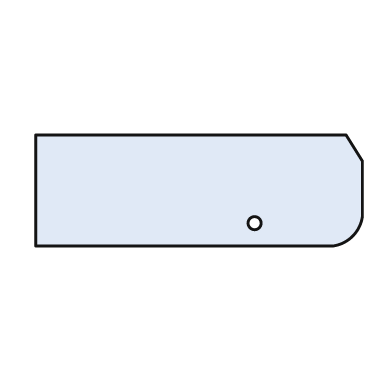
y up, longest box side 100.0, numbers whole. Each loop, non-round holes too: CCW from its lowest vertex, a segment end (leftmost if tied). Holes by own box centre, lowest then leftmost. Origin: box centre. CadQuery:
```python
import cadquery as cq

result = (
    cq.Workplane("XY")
    .moveTo(-50.0, -17.0)
    .lineTo(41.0, -17.0)
    .threePointArc((47.0, -14.0), (50.0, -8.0))
    .lineTo(50.0, 9.0)
    .lineTo(45.0, 17.0)
    .lineTo(-50.0, 17.0)
    .close()
    .moveTo(17.0, -10.0)
    .circle(2.0)
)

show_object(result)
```